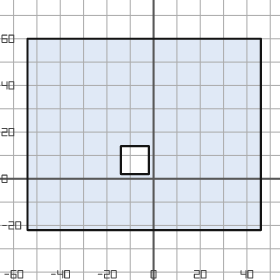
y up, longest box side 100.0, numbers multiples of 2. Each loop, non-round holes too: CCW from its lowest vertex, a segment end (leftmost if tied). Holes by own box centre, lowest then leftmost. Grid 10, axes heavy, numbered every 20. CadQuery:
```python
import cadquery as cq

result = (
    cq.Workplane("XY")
    .moveTo(-54.0, -22.0)
    .lineTo(46.0, -22.0)
    .lineTo(46.0, 60.0)
    .lineTo(-54.0, 60.0)
    .close()
    .moveTo(-14.0, 2.0)
    .lineTo(-2.0, 2.0)
    .lineTo(-2.0, 14.0)
    .lineTo(-14.0, 14.0)
    .close()
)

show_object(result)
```